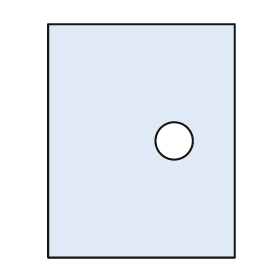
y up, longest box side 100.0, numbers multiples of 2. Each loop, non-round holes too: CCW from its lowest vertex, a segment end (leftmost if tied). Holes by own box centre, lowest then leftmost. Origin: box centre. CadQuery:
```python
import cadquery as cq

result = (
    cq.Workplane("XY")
    .moveTo(-40.0, -50.0)
    .lineTo(40.0, -50.0)
    .lineTo(40.0, 50.0)
    .lineTo(-40.0, 50.0)
    .close()
    .moveTo(14.0, 0.0)
    .circle(8.0)
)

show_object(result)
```